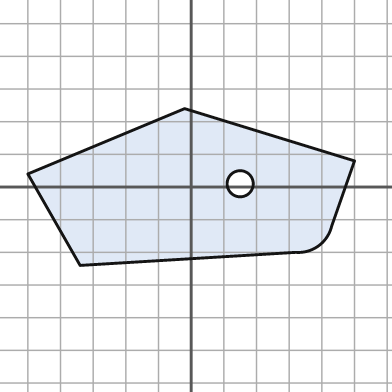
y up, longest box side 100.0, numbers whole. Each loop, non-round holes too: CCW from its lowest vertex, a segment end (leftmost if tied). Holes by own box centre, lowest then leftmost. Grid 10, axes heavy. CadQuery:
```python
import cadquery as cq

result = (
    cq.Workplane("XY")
    .moveTo(-34.0, -24.0)
    .lineTo(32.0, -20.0)
    .threePointArc((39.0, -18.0), (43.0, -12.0))
    .lineTo(50.0, 8.0)
    .lineTo(-2.0, 24.0)
    .lineTo(-50.0, 4.0)
    .close()
    .moveTo(15.0, 1.0)
    .circle(4.0)
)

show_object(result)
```